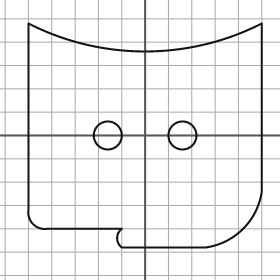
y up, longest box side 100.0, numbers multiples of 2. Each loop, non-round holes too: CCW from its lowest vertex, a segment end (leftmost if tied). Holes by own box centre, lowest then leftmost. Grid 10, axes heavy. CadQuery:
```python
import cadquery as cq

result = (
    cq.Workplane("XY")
    .moveTo(-10.0, -48.0)
    .lineTo(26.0, -48.0)
    .threePointArc((42.0, -40.0), (50.0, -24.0))
    .lineTo(50.0, 48.0)
    .threePointArc((0.0, 36.0), (-50.0, 48.0))
    .lineTo(-50.0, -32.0)
    .threePointArc((-48.0, -38.0), (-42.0, -40.0))
    .lineTo(-10.0, -40.0)
    .threePointArc((-12.0, -44.0), (-10.0, -48.0))
    .close()
    .moveTo(-16.0, 0.0)
    .circle(6.0)
    .moveTo(16.0, 0.0)
    .circle(6.0)
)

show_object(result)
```